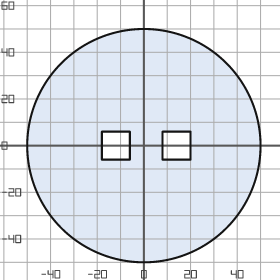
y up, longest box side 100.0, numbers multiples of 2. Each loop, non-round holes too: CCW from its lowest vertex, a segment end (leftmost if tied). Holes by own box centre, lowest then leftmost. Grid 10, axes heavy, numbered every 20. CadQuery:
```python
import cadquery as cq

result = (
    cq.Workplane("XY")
    .moveTo(0.0, 0.0)
    .circle(50.0)
    .moveTo(-18.0, -6.0)
    .lineTo(-6.0, -6.0)
    .lineTo(-6.0, 6.0)
    .lineTo(-18.0, 6.0)
    .close()
    .moveTo(8.0, -6.0)
    .lineTo(20.0, -6.0)
    .lineTo(20.0, 6.0)
    .lineTo(8.0, 6.0)
    .close()
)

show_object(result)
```